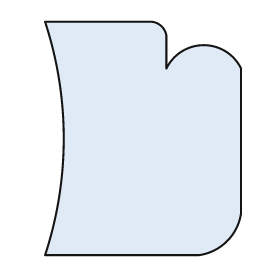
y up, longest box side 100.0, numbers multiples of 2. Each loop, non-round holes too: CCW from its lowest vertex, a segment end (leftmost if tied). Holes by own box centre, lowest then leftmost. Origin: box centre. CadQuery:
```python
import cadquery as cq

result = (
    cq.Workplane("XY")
    .moveTo(-42.0, -50.0)
    .lineTo(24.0, -50.0)
    .threePointArc((36.0, -44.0), (42.0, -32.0))
    .lineTo(42.0, 30.0)
    .threePointArc((26.0, 40.0), (10.0, 30.0))
    .lineTo(10.0, 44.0)
    .threePointArc((8.0, 48.0), (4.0, 50.0))
    .lineTo(-42.0, 50.0)
    .threePointArc((-34.0, 0.0), (-42.0, -50.0))
    .close()
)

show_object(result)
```